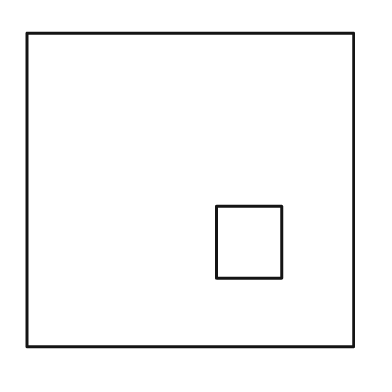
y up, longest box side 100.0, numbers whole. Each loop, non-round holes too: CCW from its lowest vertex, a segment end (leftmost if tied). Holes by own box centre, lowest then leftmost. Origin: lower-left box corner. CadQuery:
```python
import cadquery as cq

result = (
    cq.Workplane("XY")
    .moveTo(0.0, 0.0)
    .lineTo(100.0, 0.0)
    .lineTo(100.0, 96.0)
    .lineTo(0.0, 96.0)
    .close()
    .moveTo(58.0, 21.0)
    .lineTo(78.0, 21.0)
    .lineTo(78.0, 43.0)
    .lineTo(58.0, 43.0)
    .close()
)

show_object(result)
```